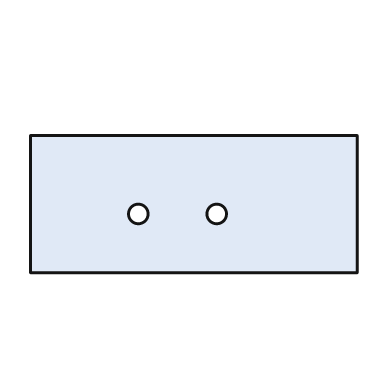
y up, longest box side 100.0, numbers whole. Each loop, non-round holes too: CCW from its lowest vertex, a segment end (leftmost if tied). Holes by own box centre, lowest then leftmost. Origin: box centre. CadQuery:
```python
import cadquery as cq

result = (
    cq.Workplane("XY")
    .moveTo(-50.0, -21.0)
    .lineTo(50.0, -21.0)
    .lineTo(50.0, 21.0)
    .lineTo(-50.0, 21.0)
    .close()
    .moveTo(-17.0, -3.0)
    .circle(3.0)
    .moveTo(7.0, -3.0)
    .circle(3.0)
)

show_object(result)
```